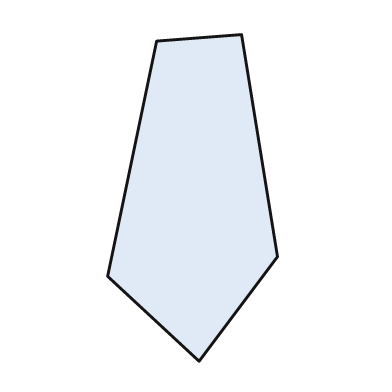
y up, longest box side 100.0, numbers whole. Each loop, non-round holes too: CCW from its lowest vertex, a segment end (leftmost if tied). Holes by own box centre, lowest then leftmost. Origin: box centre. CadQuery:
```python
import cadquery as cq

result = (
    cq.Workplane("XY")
    .moveTo(2.0, -50.0)
    .lineTo(26.0, -18.0)
    .lineTo(15.0, 50.0)
    .lineTo(-11.0, 48.0)
    .lineTo(-26.0, -24.0)
    .close()
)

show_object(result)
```